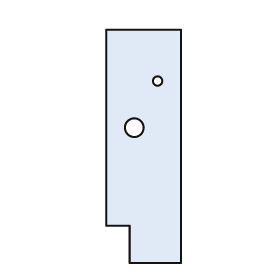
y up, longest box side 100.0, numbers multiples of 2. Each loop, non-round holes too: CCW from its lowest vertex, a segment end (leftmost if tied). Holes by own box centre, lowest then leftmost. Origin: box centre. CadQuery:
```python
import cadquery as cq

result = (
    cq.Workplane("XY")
    .moveTo(-6.0, -50.0)
    .lineTo(16.0, -50.0)
    .lineTo(16.0, 50.0)
    .lineTo(-16.0, 50.0)
    .lineTo(-16.0, -34.0)
    .lineTo(-6.0, -34.0)
    .close()
    .moveTo(-4.0, 8.0)
    .circle(4.0)
    .moveTo(6.0, 28.0)
    .circle(2.0)
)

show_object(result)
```